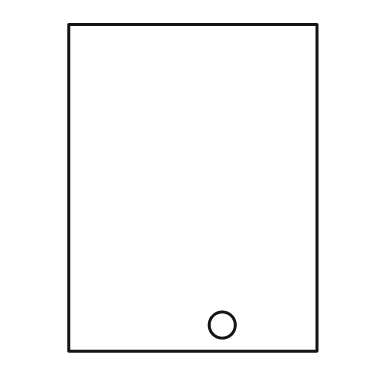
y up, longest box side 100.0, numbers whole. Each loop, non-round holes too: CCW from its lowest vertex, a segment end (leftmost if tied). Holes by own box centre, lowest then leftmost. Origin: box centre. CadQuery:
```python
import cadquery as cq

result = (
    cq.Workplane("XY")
    .moveTo(-38.0, -50.0)
    .lineTo(38.0, -50.0)
    .lineTo(38.0, 50.0)
    .lineTo(-38.0, 50.0)
    .close()
    .moveTo(9.0, -42.0)
    .circle(4.0)
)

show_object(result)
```